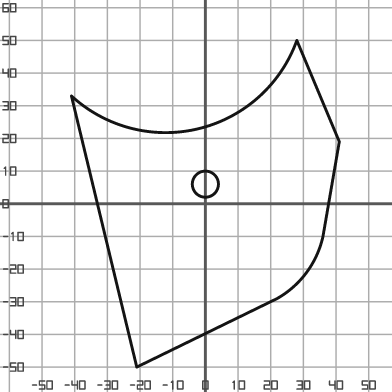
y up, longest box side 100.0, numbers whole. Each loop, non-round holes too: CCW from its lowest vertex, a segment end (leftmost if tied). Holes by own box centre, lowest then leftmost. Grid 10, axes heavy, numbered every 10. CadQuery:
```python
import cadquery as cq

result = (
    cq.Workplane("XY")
    .moveTo(-21.0, -50.0)
    .lineTo(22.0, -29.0)
    .threePointArc((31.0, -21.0), (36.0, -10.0))
    .lineTo(41.0, 19.0)
    .lineTo(28.0, 50.0)
    .threePointArc((-2.0, 23.0), (-41.0, 33.0))
    .close()
    .moveTo(0.0, 6.0)
    .circle(4.0)
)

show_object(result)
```